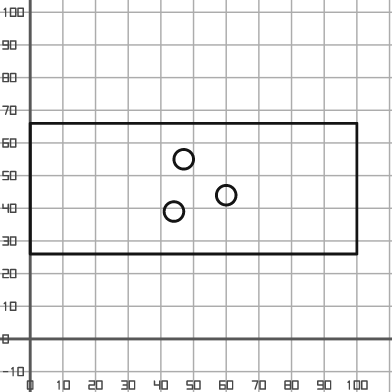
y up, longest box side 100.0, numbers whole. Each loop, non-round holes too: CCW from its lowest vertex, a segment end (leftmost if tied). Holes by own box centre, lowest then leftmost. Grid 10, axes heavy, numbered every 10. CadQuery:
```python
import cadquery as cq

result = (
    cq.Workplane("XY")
    .moveTo(0.0, 26.0)
    .lineTo(100.0, 26.0)
    .lineTo(100.0, 66.0)
    .lineTo(0.0, 66.0)
    .close()
    .moveTo(44.0, 39.0)
    .circle(3.0)
    .moveTo(60.0, 44.0)
    .circle(3.0)
    .moveTo(47.0, 55.0)
    .circle(3.0)
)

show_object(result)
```